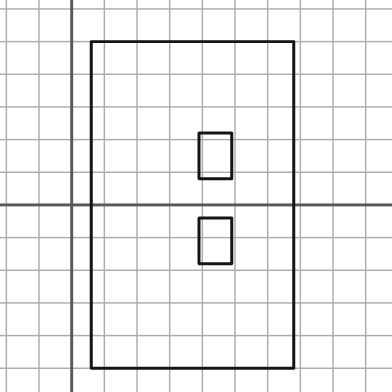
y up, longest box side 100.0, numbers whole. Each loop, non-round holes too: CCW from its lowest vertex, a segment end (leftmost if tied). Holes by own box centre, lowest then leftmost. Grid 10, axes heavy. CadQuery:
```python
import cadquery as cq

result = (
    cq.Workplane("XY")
    .moveTo(6.0, -50.0)
    .lineTo(68.0, -50.0)
    .lineTo(68.0, 50.0)
    .lineTo(6.0, 50.0)
    .close()
    .moveTo(39.0, -18.0)
    .lineTo(49.0, -18.0)
    .lineTo(49.0, -4.0)
    .lineTo(39.0, -4.0)
    .close()
    .moveTo(39.0, 8.0)
    .lineTo(49.0, 8.0)
    .lineTo(49.0, 22.0)
    .lineTo(39.0, 22.0)
    .close()
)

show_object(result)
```